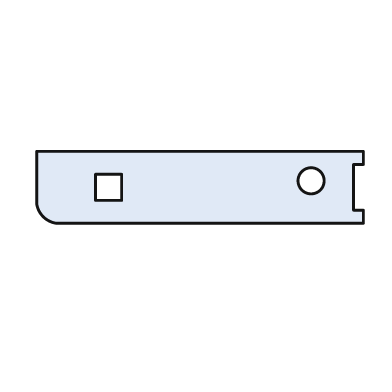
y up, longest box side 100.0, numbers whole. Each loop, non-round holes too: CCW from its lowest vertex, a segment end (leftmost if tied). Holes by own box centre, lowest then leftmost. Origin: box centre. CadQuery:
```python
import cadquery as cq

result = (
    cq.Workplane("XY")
    .moveTo(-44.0, -11.0)
    .lineTo(50.0, -11.0)
    .lineTo(50.0, -7.0)
    .lineTo(47.0, -7.0)
    .lineTo(47.0, 7.0)
    .lineTo(50.0, 7.0)
    .lineTo(50.0, 11.0)
    .lineTo(-50.0, 11.0)
    .lineTo(-50.0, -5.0)
    .threePointArc((-48.0, -9.0), (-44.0, -11.0))
    .close()
    .moveTo(-32.0, -4.0)
    .lineTo(-24.0, -4.0)
    .lineTo(-24.0, 4.0)
    .lineTo(-32.0, 4.0)
    .close()
    .moveTo(34.0, 2.0)
    .circle(4.0)
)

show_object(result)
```